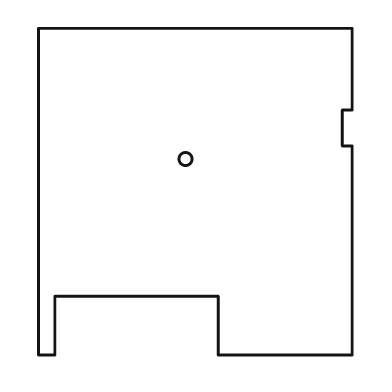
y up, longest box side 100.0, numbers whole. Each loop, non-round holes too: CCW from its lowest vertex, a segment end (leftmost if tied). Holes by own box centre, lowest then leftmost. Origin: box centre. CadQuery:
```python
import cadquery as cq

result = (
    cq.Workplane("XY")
    .moveTo(-48.0, -50.0)
    .lineTo(-43.0, -50.0)
    .lineTo(-43.0, -32.0)
    .lineTo(7.0, -32.0)
    .lineTo(7.0, -50.0)
    .lineTo(48.0, -50.0)
    .lineTo(48.0, 14.0)
    .lineTo(45.0, 14.0)
    .lineTo(45.0, 25.0)
    .lineTo(48.0, 25.0)
    .lineTo(48.0, 50.0)
    .lineTo(-48.0, 50.0)
    .close()
    .moveTo(-3.0, 10.0)
    .circle(2.0)
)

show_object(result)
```